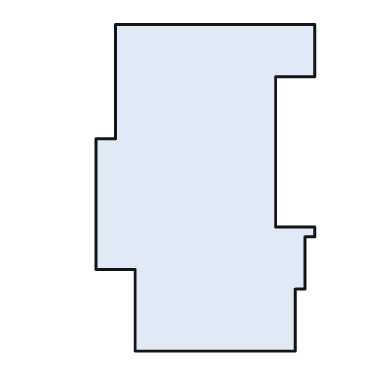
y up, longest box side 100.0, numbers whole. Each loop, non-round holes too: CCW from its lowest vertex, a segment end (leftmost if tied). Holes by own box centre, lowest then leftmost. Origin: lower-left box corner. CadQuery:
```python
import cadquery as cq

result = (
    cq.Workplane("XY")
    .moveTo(12.0, 0.0)
    .lineTo(61.0, 0.0)
    .lineTo(61.0, 19.0)
    .lineTo(64.0, 19.0)
    .lineTo(64.0, 35.0)
    .lineTo(67.0, 35.0)
    .lineTo(67.0, 38.0)
    .lineTo(55.0, 38.0)
    .lineTo(55.0, 84.0)
    .lineTo(67.0, 84.0)
    .lineTo(67.0, 100.0)
    .lineTo(6.0, 100.0)
    .lineTo(6.0, 65.0)
    .lineTo(0.0, 65.0)
    .lineTo(0.0, 25.0)
    .lineTo(12.0, 25.0)
    .close()
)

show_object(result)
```